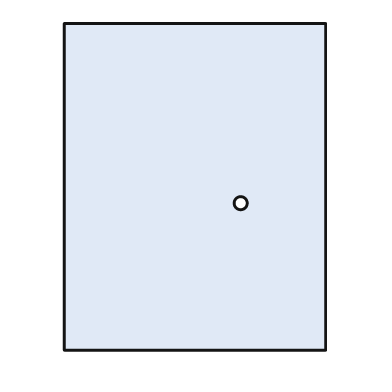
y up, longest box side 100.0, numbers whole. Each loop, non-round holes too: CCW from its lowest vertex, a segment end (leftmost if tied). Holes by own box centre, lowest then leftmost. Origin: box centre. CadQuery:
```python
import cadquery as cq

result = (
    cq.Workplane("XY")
    .moveTo(-40.0, -50.0)
    .lineTo(40.0, -50.0)
    .lineTo(40.0, 50.0)
    .lineTo(-40.0, 50.0)
    .close()
    .moveTo(14.0, -5.0)
    .circle(2.0)
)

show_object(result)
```